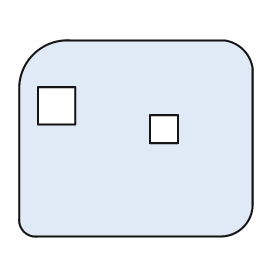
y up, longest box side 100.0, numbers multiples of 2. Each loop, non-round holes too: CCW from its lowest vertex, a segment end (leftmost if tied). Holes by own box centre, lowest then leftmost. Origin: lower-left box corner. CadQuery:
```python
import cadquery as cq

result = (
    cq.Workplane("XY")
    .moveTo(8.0, 0.0)
    .lineTo(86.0, 0.0)
    .threePointArc((96.0, 4.0), (100.0, 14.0))
    .lineTo(100.0, 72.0)
    .threePointArc((96.0, 80.0), (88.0, 84.0))
    .lineTo(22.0, 84.0)
    .threePointArc((6.0, 78.0), (0.0, 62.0))
    .lineTo(0.0, 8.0)
    .threePointArc((2.0, 2.0), (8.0, 0.0))
    .close()
    .moveTo(56.0, 40.0)
    .lineTo(68.0, 40.0)
    .lineTo(68.0, 52.0)
    .lineTo(56.0, 52.0)
    .close()
    .moveTo(8.0, 48.0)
    .lineTo(24.0, 48.0)
    .lineTo(24.0, 64.0)
    .lineTo(8.0, 64.0)
    .close()
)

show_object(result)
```